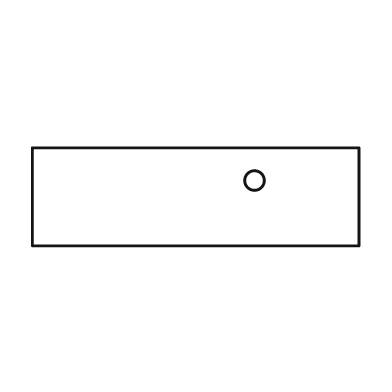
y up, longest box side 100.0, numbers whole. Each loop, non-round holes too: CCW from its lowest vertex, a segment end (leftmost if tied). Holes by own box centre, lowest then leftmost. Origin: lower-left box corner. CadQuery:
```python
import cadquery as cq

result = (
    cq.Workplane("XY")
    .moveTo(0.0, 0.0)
    .lineTo(100.0, 0.0)
    .lineTo(100.0, 30.0)
    .lineTo(0.0, 30.0)
    .close()
    .moveTo(68.0, 20.0)
    .circle(3.0)
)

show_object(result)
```